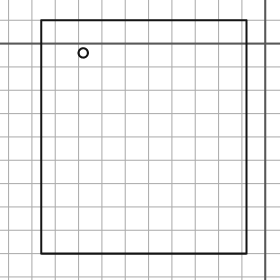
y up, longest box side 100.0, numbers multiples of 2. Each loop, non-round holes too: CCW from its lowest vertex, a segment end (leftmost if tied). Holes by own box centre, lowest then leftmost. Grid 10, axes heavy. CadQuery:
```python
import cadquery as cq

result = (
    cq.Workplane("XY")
    .moveTo(-96.0, -90.0)
    .lineTo(-8.0, -90.0)
    .lineTo(-8.0, 10.0)
    .lineTo(-96.0, 10.0)
    .close()
    .moveTo(-78.0, -4.0)
    .circle(2.0)
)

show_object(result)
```